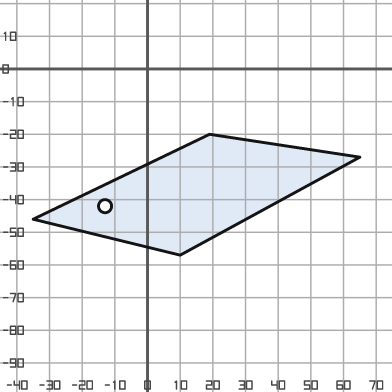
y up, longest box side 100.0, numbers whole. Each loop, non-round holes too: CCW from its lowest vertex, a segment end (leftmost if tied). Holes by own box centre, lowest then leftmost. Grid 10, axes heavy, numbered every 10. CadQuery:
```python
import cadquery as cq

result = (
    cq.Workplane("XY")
    .moveTo(10.0, -57.0)
    .lineTo(65.0, -27.0)
    .lineTo(19.0, -20.0)
    .lineTo(-35.0, -46.0)
    .close()
    .moveTo(-13.0, -42.0)
    .circle(2.0)
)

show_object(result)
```